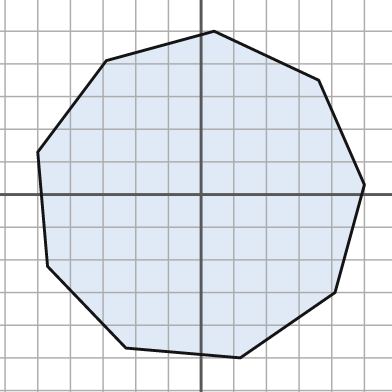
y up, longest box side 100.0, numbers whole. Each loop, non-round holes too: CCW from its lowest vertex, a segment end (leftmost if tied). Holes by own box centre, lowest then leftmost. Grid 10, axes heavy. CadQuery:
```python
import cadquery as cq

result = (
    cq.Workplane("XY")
    .moveTo(12.0, -50.0)
    .lineTo(41.0, -30.0)
    .lineTo(50.0, 3.0)
    .lineTo(36.0, 35.0)
    .lineTo(4.0, 50.0)
    .lineTo(-29.0, 41.0)
    .lineTo(-50.0, 13.0)
    .lineTo(-47.0, -22.0)
    .lineTo(-23.0, -47.0)
    .close()
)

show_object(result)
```